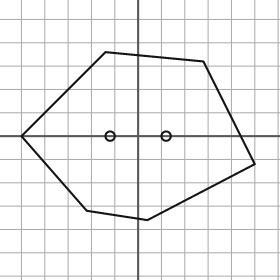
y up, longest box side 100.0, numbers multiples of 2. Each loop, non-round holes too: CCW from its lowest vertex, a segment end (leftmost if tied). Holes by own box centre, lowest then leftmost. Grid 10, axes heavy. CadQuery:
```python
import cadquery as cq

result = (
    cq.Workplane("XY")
    .moveTo(4.0, -36.0)
    .lineTo(50.0, -12.0)
    .lineTo(28.0, 32.0)
    .lineTo(-14.0, 36.0)
    .lineTo(-50.0, 0.0)
    .lineTo(-22.0, -32.0)
    .close()
    .moveTo(-12.0, 0.0)
    .circle(2.0)
    .moveTo(12.0, 0.0)
    .circle(2.0)
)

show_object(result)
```